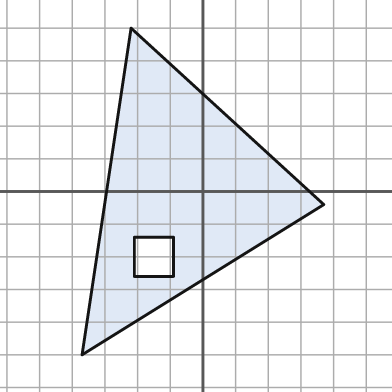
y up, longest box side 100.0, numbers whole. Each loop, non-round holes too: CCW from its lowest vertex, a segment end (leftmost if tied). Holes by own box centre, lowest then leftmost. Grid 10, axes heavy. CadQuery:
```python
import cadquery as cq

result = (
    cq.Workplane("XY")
    .moveTo(-37.0, -50.0)
    .lineTo(37.0, -4.0)
    .lineTo(-22.0, 50.0)
    .close()
    .moveTo(-21.0, -26.0)
    .lineTo(-9.0, -26.0)
    .lineTo(-9.0, -14.0)
    .lineTo(-21.0, -14.0)
    .close()
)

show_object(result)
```